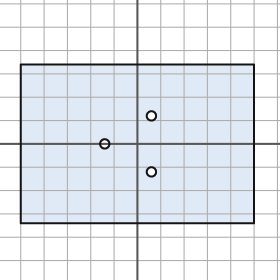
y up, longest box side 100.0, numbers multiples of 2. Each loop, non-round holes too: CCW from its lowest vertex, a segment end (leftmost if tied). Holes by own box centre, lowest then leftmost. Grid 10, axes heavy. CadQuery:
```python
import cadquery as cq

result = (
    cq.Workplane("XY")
    .moveTo(-50.0, -34.0)
    .lineTo(50.0, -34.0)
    .lineTo(50.0, 34.0)
    .lineTo(-50.0, 34.0)
    .close()
    .moveTo(6.0, -12.0)
    .circle(2.0)
    .moveTo(-14.0, 0.0)
    .circle(2.0)
    .moveTo(6.0, 12.0)
    .circle(2.0)
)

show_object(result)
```